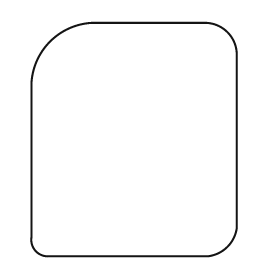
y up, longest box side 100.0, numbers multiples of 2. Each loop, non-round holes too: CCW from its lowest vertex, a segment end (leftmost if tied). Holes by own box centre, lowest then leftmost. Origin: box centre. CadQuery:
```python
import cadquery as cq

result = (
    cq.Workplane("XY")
    .moveTo(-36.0, -50.0)
    .lineTo(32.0, -50.0)
    .threePointArc((40.0, -46.0), (44.0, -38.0))
    .lineTo(44.0, 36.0)
    .threePointArc((40.0, 46.0), (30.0, 50.0))
    .lineTo(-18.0, 50.0)
    .threePointArc((-36.0, 42.0), (-44.0, 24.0))
    .lineTo(-44.0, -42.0)
    .threePointArc((-42.0, -48.0), (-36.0, -50.0))
    .close()
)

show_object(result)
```